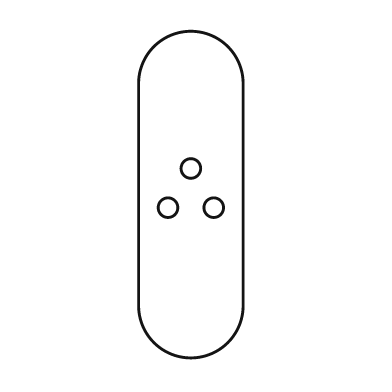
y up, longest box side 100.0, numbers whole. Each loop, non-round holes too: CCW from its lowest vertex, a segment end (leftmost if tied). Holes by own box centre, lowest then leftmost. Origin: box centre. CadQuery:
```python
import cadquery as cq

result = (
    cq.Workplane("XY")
    .moveTo(-16.0, -34.0)
    .threePointArc((0.0, -50.0), (16.0, -34.0))
    .lineTo(16.0, 34.0)
    .threePointArc((0.0, 50.0), (-16.0, 34.0))
    .close()
    .moveTo(-7.0, -4.0)
    .circle(3.0)
    .moveTo(7.0, -4.0)
    .circle(3.0)
    .moveTo(0.0, 8.0)
    .circle(3.0)
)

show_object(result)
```